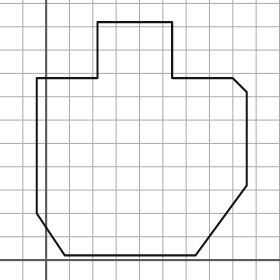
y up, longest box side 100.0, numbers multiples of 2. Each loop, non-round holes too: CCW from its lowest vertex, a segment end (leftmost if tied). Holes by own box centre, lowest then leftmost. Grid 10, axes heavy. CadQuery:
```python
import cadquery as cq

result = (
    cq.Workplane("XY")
    .moveTo(8.0, 2.0)
    .lineTo(64.0, 2.0)
    .lineTo(86.0, 32.0)
    .lineTo(86.0, 72.0)
    .lineTo(80.0, 78.0)
    .lineTo(54.0, 78.0)
    .lineTo(54.0, 102.0)
    .lineTo(22.0, 102.0)
    .lineTo(22.0, 78.0)
    .lineTo(-4.0, 78.0)
    .lineTo(-4.0, 20.0)
    .close()
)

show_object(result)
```